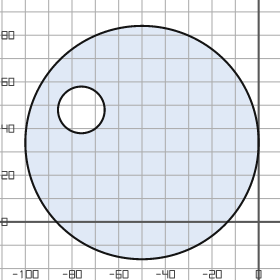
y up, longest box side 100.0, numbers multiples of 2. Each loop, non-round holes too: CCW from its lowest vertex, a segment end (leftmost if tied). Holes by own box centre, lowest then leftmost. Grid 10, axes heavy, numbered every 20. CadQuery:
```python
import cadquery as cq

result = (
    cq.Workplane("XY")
    .moveTo(-50.0, 34.0)
    .circle(50.0)
    .moveTo(-76.0, 48.0)
    .circle(10.0)
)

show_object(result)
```